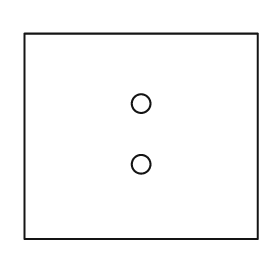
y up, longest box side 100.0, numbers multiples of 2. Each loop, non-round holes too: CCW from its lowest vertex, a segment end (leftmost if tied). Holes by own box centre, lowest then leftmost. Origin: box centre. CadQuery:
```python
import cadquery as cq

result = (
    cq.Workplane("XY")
    .moveTo(-50.0, -44.0)
    .lineTo(50.0, -44.0)
    .lineTo(50.0, 44.0)
    .lineTo(-50.0, 44.0)
    .close()
    .moveTo(0.0, -12.0)
    .circle(4.0)
    .moveTo(0.0, 14.0)
    .circle(4.0)
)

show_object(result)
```